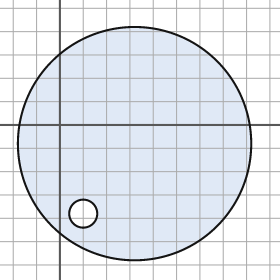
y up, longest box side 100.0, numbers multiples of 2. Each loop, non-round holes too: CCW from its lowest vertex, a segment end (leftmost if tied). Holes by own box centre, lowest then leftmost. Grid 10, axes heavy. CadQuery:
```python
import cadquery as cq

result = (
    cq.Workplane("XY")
    .moveTo(32.0, -8.0)
    .circle(50.0)
    .moveTo(10.0, -38.0)
    .circle(6.0)
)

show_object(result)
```